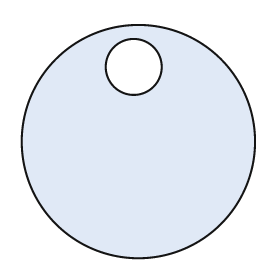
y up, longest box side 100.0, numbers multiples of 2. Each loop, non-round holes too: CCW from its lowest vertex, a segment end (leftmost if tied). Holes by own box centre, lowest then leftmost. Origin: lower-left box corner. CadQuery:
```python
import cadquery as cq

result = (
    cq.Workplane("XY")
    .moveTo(50.0, 50.0)
    .circle(50.0)
    .moveTo(48.0, 82.0)
    .circle(12.0)
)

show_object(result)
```